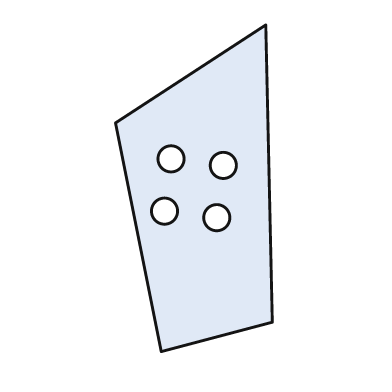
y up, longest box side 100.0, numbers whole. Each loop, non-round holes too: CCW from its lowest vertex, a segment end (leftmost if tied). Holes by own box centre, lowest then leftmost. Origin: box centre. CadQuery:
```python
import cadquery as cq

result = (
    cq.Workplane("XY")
    .moveTo(-10.0, -50.0)
    .lineTo(24.0, -41.0)
    .lineTo(22.0, 50.0)
    .lineTo(-24.0, 20.0)
    .close()
    .moveTo(7.0, -9.0)
    .circle(4.0)
    .moveTo(-9.0, -7.0)
    .circle(4.0)
    .moveTo(9.0, 7.0)
    .circle(4.0)
    .moveTo(-7.0, 9.0)
    .circle(4.0)
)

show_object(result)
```